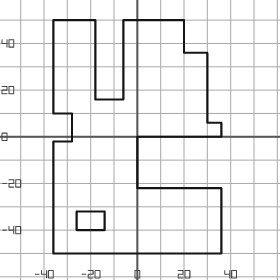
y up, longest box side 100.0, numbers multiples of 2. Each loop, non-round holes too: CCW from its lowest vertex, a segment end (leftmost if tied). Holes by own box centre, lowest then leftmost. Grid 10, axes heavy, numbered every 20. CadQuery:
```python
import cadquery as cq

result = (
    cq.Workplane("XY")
    .moveTo(-36.0, -50.0)
    .lineTo(36.0, -50.0)
    .lineTo(36.0, -22.0)
    .lineTo(0.0, -22.0)
    .lineTo(0.0, 0.0)
    .lineTo(36.0, 0.0)
    .lineTo(36.0, 6.0)
    .lineTo(30.0, 6.0)
    .lineTo(30.0, 36.0)
    .lineTo(20.0, 36.0)
    .lineTo(20.0, 50.0)
    .lineTo(-6.0, 50.0)
    .lineTo(-6.0, 16.0)
    .lineTo(-18.0, 16.0)
    .lineTo(-18.0, 50.0)
    .lineTo(-36.0, 50.0)
    .lineTo(-36.0, 10.0)
    .lineTo(-28.0, 10.0)
    .lineTo(-28.0, -2.0)
    .lineTo(-36.0, -2.0)
    .close()
    .moveTo(-26.0, -40.0)
    .lineTo(-14.0, -40.0)
    .lineTo(-14.0, -32.0)
    .lineTo(-26.0, -32.0)
    .close()
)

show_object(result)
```